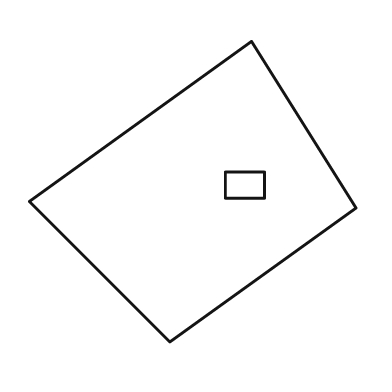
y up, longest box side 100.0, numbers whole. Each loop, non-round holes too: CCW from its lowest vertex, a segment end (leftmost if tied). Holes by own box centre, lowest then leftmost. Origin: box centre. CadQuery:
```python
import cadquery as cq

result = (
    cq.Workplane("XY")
    .moveTo(-7.0, -46.0)
    .lineTo(50.0, -5.0)
    .lineTo(18.0, 46.0)
    .lineTo(-50.0, -3.0)
    .close()
    .moveTo(10.0, -2.0)
    .lineTo(22.0, -2.0)
    .lineTo(22.0, 6.0)
    .lineTo(10.0, 6.0)
    .close()
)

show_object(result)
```